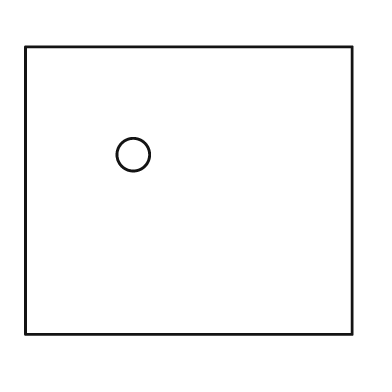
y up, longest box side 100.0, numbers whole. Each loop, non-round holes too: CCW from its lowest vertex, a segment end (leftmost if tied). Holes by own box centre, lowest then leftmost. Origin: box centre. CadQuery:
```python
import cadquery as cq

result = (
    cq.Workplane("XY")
    .moveTo(-50.0, -44.0)
    .lineTo(50.0, -44.0)
    .lineTo(50.0, 44.0)
    .lineTo(-50.0, 44.0)
    .close()
    .moveTo(-17.0, 11.0)
    .circle(5.0)
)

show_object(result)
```